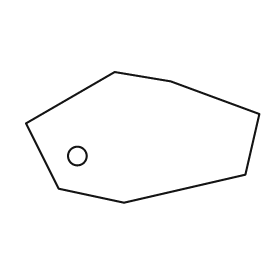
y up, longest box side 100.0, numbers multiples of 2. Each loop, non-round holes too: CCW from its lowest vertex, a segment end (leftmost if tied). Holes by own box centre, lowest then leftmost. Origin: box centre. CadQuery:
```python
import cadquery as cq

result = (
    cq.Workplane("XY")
    .moveTo(-8.0, -28.0)
    .lineTo(44.0, -16.0)
    .lineTo(50.0, 10.0)
    .lineTo(12.0, 24.0)
    .lineTo(-12.0, 28.0)
    .lineTo(-50.0, 6.0)
    .lineTo(-36.0, -22.0)
    .close()
    .moveTo(-28.0, -8.0)
    .circle(4.0)
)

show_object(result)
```